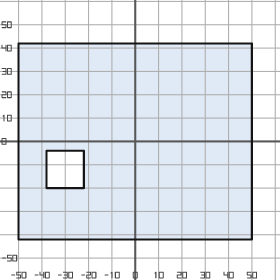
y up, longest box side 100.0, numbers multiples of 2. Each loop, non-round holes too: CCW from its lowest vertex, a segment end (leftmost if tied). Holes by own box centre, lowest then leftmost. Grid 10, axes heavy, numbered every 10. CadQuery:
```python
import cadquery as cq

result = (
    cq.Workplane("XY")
    .moveTo(-50.0, -42.0)
    .lineTo(50.0, -42.0)
    .lineTo(50.0, 42.0)
    .lineTo(-50.0, 42.0)
    .close()
    .moveTo(-38.0, -20.0)
    .lineTo(-22.0, -20.0)
    .lineTo(-22.0, -4.0)
    .lineTo(-38.0, -4.0)
    .close()
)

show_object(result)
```